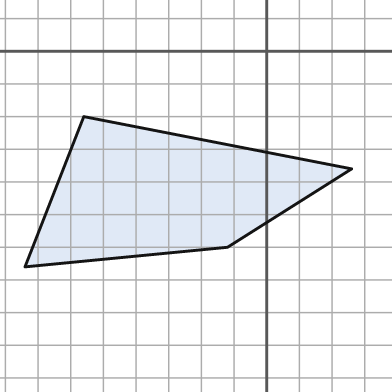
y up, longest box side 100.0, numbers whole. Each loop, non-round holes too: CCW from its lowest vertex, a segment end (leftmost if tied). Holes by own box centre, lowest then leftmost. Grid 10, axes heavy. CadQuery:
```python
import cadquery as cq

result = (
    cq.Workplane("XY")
    .moveTo(-74.0, -66.0)
    .lineTo(-12.0, -60.0)
    .lineTo(26.0, -36.0)
    .lineTo(-56.0, -20.0)
    .close()
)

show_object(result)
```